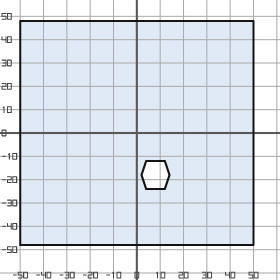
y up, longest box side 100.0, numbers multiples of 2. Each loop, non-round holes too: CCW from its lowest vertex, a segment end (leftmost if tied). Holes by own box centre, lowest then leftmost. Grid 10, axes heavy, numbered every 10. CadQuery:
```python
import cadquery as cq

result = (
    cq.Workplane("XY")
    .moveTo(-50.0, -48.0)
    .lineTo(50.0, -48.0)
    .lineTo(50.0, 48.0)
    .lineTo(-50.0, 48.0)
    .close()
    .moveTo(4.0, -24.0)
    .lineTo(12.0, -24.0)
    .lineTo(14.0, -18.0)
    .lineTo(12.0, -12.0)
    .lineTo(4.0, -12.0)
    .lineTo(2.0, -18.0)
    .close()
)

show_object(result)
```